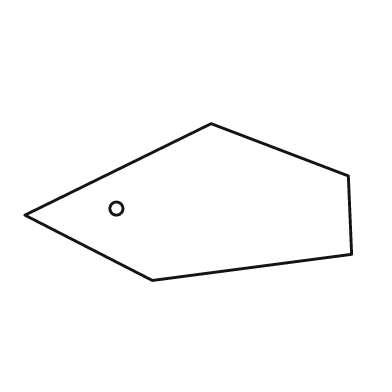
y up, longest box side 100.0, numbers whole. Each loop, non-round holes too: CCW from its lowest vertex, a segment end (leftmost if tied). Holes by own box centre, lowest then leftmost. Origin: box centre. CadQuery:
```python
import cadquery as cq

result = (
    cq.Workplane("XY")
    .moveTo(-11.0, -24.0)
    .lineTo(50.0, -16.0)
    .lineTo(49.0, 8.0)
    .lineTo(7.0, 24.0)
    .lineTo(-50.0, -4.0)
    .close()
    .moveTo(-22.0, -2.0)
    .circle(2.0)
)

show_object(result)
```